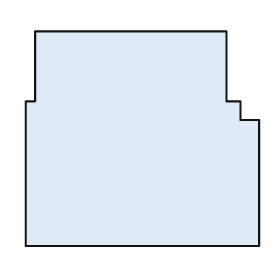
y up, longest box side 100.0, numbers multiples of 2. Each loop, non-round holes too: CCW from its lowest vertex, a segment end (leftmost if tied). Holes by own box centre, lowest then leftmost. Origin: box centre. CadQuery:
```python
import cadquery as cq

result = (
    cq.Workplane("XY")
    .moveTo(-50.0, -46.0)
    .lineTo(50.0, -46.0)
    .lineTo(50.0, 8.0)
    .lineTo(42.0, 8.0)
    .lineTo(42.0, 16.0)
    .lineTo(36.0, 16.0)
    .lineTo(36.0, 46.0)
    .lineTo(-46.0, 46.0)
    .lineTo(-46.0, 16.0)
    .lineTo(-50.0, 16.0)
    .close()
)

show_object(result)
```